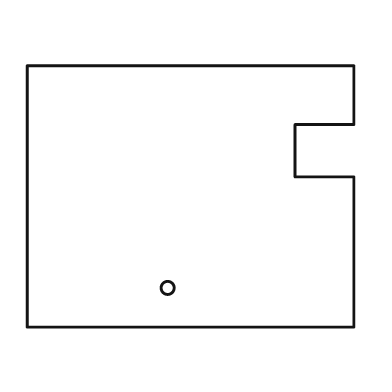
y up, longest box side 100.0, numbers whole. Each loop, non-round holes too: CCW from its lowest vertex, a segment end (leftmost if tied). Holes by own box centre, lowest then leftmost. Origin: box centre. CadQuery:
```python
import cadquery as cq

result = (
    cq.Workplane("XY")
    .moveTo(-50.0, -40.0)
    .lineTo(50.0, -40.0)
    .lineTo(50.0, 6.0)
    .lineTo(32.0, 6.0)
    .lineTo(32.0, 22.0)
    .lineTo(50.0, 22.0)
    .lineTo(50.0, 40.0)
    .lineTo(-50.0, 40.0)
    .close()
    .moveTo(-7.0, -28.0)
    .circle(2.0)
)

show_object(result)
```